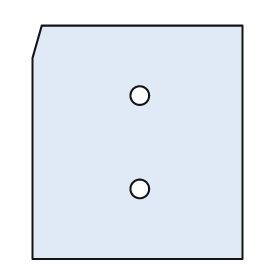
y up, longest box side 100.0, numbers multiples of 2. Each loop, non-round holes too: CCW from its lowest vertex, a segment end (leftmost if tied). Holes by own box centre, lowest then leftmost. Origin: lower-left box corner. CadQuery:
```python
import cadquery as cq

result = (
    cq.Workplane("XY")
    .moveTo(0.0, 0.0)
    .lineTo(90.0, 0.0)
    .lineTo(90.0, 100.0)
    .lineTo(4.0, 100.0)
    .lineTo(0.0, 86.0)
    .close()
    .moveTo(46.0, 30.0)
    .circle(4.0)
    .moveTo(46.0, 70.0)
    .circle(4.0)
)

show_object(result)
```